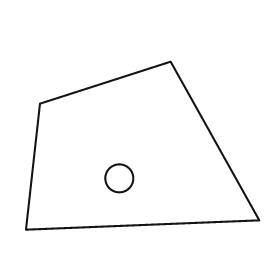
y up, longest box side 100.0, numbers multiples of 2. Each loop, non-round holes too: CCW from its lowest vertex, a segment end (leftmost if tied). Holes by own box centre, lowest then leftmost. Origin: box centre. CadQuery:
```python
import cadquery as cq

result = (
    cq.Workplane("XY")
    .moveTo(-50.0, -36.0)
    .lineTo(50.0, -32.0)
    .lineTo(12.0, 36.0)
    .lineTo(-44.0, 18.0)
    .close()
    .moveTo(-10.0, -14.0)
    .circle(6.0)
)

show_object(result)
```